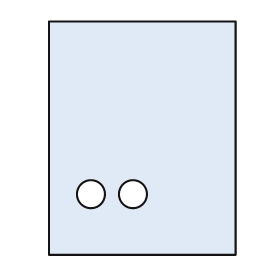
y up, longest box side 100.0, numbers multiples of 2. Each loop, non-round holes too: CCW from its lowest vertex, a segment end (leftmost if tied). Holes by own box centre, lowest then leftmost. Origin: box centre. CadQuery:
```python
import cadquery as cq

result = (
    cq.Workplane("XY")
    .moveTo(-40.0, -50.0)
    .lineTo(40.0, -50.0)
    .lineTo(40.0, 50.0)
    .lineTo(-40.0, 50.0)
    .close()
    .moveTo(-22.0, -24.0)
    .circle(6.0)
    .moveTo(-4.0, -24.0)
    .circle(6.0)
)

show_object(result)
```